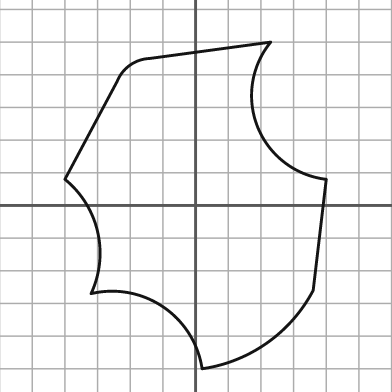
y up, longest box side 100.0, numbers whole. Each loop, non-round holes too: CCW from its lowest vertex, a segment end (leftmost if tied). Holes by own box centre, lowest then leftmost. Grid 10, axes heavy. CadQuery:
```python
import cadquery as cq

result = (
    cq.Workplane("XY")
    .moveTo(2.0, -50.0)
    .threePointArc((22.0, -42.0), (36.0, -26.0))
    .lineTo(40.0, 8.0)
    .threePointArc((19.0, 24.0), (23.0, 50.0))
    .lineTo(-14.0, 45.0)
    .threePointArc((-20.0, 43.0), (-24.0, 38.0))
    .lineTo(-40.0, 8.0)
    .threePointArc((-30.0, -8.0), (-32.0, -27.0))
    .threePointArc((-10.0, -31.0), (2.0, -50.0))
    .close()
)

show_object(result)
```